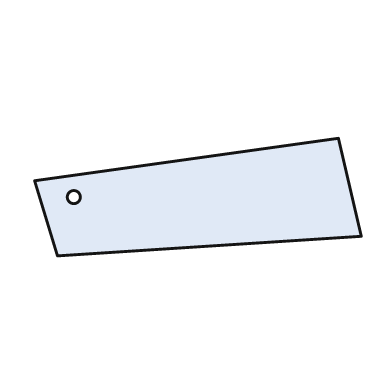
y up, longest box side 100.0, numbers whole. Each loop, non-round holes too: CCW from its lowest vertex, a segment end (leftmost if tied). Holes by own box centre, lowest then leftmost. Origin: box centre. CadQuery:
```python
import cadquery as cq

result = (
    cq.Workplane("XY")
    .moveTo(-43.0, -18.0)
    .lineTo(50.0, -12.0)
    .lineTo(43.0, 18.0)
    .lineTo(-50.0, 5.0)
    .close()
    .moveTo(-38.0, 0.0)
    .circle(2.0)
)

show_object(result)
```